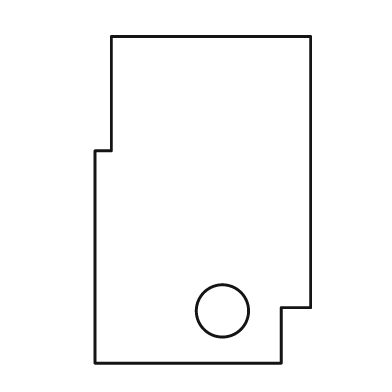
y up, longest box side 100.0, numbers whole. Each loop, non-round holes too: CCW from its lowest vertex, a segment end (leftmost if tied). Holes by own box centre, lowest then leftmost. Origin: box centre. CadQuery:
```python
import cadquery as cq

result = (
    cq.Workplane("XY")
    .moveTo(-33.0, -50.0)
    .lineTo(24.0, -50.0)
    .lineTo(24.0, -33.0)
    .lineTo(33.0, -33.0)
    .lineTo(33.0, 50.0)
    .lineTo(-28.0, 50.0)
    .lineTo(-28.0, 15.0)
    .lineTo(-33.0, 15.0)
    .close()
    .moveTo(6.0, -34.0)
    .circle(8.0)
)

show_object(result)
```